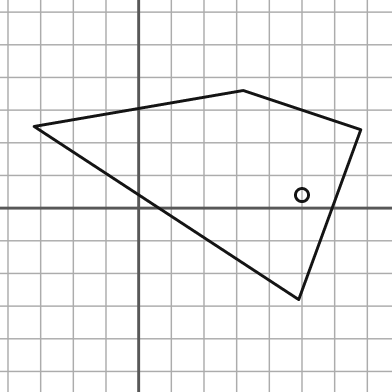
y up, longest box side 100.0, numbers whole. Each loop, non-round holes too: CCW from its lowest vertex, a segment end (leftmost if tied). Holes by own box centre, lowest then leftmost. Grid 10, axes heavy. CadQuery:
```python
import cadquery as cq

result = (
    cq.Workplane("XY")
    .moveTo(49.0, -28.0)
    .lineTo(68.0, 24.0)
    .lineTo(32.0, 36.0)
    .lineTo(-32.0, 25.0)
    .close()
    .moveTo(50.0, 4.0)
    .circle(2.0)
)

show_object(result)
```